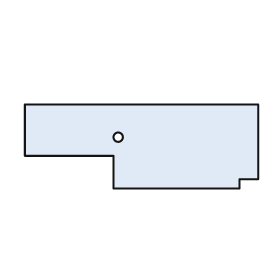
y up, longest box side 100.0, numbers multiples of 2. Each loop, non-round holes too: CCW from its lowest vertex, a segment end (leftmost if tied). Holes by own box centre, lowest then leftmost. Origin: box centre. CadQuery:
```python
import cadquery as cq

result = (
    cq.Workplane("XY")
    .moveTo(-12.0, -18.0)
    .lineTo(42.0, -18.0)
    .lineTo(42.0, -14.0)
    .lineTo(50.0, -14.0)
    .lineTo(50.0, 18.0)
    .lineTo(-50.0, 18.0)
    .lineTo(-50.0, -4.0)
    .lineTo(-12.0, -4.0)
    .close()
    .moveTo(-10.0, 4.0)
    .circle(2.0)
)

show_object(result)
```